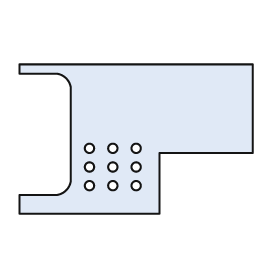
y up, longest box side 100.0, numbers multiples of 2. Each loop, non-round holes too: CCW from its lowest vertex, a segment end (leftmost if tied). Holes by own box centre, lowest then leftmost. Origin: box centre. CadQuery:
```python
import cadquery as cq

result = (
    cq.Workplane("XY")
    .moveTo(-50.0, -32.0)
    .lineTo(10.0, -32.0)
    .lineTo(10.0, -6.0)
    .lineTo(50.0, -6.0)
    .lineTo(50.0, 32.0)
    .lineTo(-50.0, 32.0)
    .lineTo(-50.0, 28.0)
    .lineTo(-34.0, 28.0)
    .threePointArc((-30.0, 26.0), (-28.0, 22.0))
    .lineTo(-28.0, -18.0)
    .threePointArc((-30.0, -22.0), (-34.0, -24.0))
    .lineTo(-50.0, -24.0)
    .close()
    .moveTo(-20.0, -20.0)
    .circle(2.0)
    .moveTo(-10.0, -20.0)
    .circle(2.0)
    .moveTo(0.0, -20.0)
    .circle(2.0)
    .moveTo(-20.0, -12.0)
    .circle(2.0)
    .moveTo(-10.0, -12.0)
    .circle(2.0)
    .moveTo(0.0, -12.0)
    .circle(2.0)
    .moveTo(-20.0, -4.0)
    .circle(2.0)
    .moveTo(-10.0, -4.0)
    .circle(2.0)
    .moveTo(0.0, -4.0)
    .circle(2.0)
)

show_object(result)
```